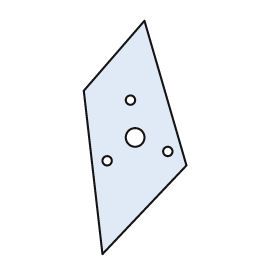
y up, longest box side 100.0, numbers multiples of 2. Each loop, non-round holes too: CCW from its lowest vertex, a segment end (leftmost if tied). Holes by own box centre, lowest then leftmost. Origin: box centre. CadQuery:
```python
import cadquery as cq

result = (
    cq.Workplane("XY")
    .moveTo(-14.0, -50.0)
    .lineTo(22.0, -12.0)
    .lineTo(4.0, 50.0)
    .lineTo(-22.0, 20.0)
    .close()
    .moveTo(-12.0, -10.0)
    .circle(2.0)
    .moveTo(14.0, -6.0)
    .circle(2.0)
    .moveTo(0.0, 0.0)
    .circle(4.0)
    .moveTo(-2.0, 16.0)
    .circle(2.0)
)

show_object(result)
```